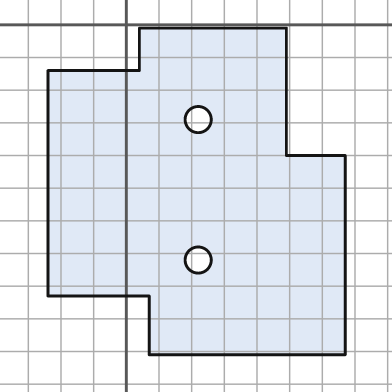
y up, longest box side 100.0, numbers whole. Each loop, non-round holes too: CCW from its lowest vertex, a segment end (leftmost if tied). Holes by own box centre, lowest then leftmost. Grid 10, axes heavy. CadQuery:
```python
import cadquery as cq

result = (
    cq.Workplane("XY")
    .moveTo(7.0, -101.0)
    .lineTo(67.0, -101.0)
    .lineTo(67.0, -40.0)
    .lineTo(49.0, -40.0)
    .lineTo(49.0, -1.0)
    .lineTo(4.0, -1.0)
    .lineTo(4.0, -14.0)
    .lineTo(-24.0, -14.0)
    .lineTo(-24.0, -83.0)
    .lineTo(7.0, -83.0)
    .close()
    .moveTo(22.0, -72.0)
    .circle(4.0)
    .moveTo(22.0, -29.0)
    .circle(4.0)
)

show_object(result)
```